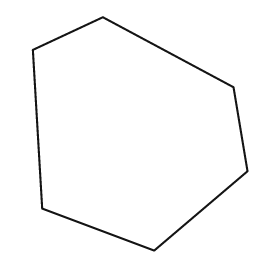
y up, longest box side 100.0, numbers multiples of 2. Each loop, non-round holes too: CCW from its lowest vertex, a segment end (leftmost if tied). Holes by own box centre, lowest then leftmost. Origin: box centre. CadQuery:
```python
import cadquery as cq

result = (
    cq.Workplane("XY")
    .moveTo(6.0, -50.0)
    .lineTo(46.0, -16.0)
    .lineTo(40.0, 20.0)
    .lineTo(-16.0, 50.0)
    .lineTo(-46.0, 36.0)
    .lineTo(-42.0, -32.0)
    .close()
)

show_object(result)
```